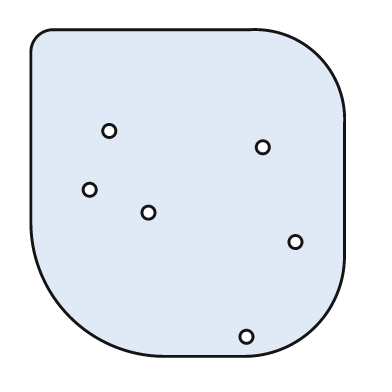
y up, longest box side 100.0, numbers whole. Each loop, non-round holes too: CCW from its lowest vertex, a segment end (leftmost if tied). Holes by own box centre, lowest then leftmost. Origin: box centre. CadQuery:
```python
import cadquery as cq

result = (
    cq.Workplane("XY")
    .moveTo(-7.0, -50.0)
    .lineTo(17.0, -50.0)
    .threePointArc((39.0, -41.0), (48.0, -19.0))
    .lineTo(48.0, 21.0)
    .threePointArc((40.0, 42.0), (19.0, 50.0))
    .lineTo(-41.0, 50.0)
    .threePointArc((-46.0, 48.0), (-48.0, 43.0))
    .lineTo(-48.0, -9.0)
    .threePointArc((-36.0, -38.0), (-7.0, -50.0))
    .close()
    .moveTo(18.0, -44.0)
    .circle(2.0)
    .moveTo(33.0, -15.0)
    .circle(2.0)
    .moveTo(-12.0, -6.0)
    .circle(2.0)
    .moveTo(-30.0, 1.0)
    .circle(2.0)
    .moveTo(23.0, 14.0)
    .circle(2.0)
    .moveTo(-24.0, 19.0)
    .circle(2.0)
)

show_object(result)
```